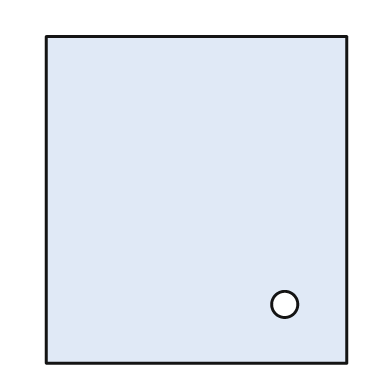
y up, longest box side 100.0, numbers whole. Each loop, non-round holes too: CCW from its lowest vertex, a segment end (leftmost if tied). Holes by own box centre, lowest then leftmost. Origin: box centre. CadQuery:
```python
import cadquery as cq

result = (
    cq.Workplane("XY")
    .moveTo(-46.0, -50.0)
    .lineTo(46.0, -50.0)
    .lineTo(46.0, 50.0)
    .lineTo(-46.0, 50.0)
    .close()
    .moveTo(27.0, -32.0)
    .circle(4.0)
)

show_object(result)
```